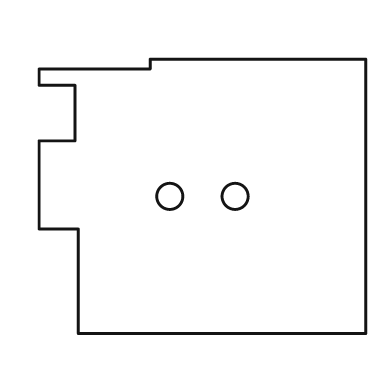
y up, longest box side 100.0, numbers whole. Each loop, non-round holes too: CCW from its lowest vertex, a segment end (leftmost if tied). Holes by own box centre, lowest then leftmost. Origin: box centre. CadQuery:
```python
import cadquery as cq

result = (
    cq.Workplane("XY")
    .moveTo(-38.0, -42.0)
    .lineTo(50.0, -42.0)
    .lineTo(50.0, 42.0)
    .lineTo(-16.0, 42.0)
    .lineTo(-16.0, 39.0)
    .lineTo(-50.0, 39.0)
    .lineTo(-50.0, 34.0)
    .lineTo(-39.0, 34.0)
    .lineTo(-39.0, 17.0)
    .lineTo(-50.0, 17.0)
    .lineTo(-50.0, -10.0)
    .lineTo(-38.0, -10.0)
    .close()
    .moveTo(-10.0, 0.0)
    .circle(4.0)
    .moveTo(10.0, 0.0)
    .circle(4.0)
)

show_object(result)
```